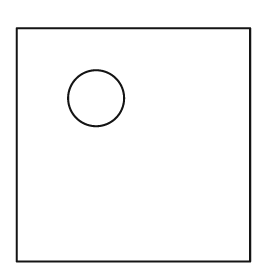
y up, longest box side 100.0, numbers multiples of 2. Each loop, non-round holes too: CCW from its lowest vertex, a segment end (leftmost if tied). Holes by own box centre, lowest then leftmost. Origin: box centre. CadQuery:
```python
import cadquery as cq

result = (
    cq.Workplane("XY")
    .moveTo(-50.0, -50.0)
    .lineTo(50.0, -50.0)
    .lineTo(50.0, 50.0)
    .lineTo(-50.0, 50.0)
    .close()
    .moveTo(-16.0, 20.0)
    .circle(12.0)
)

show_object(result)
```